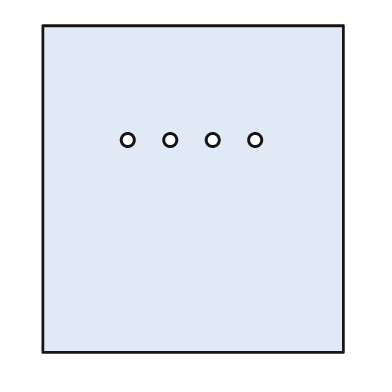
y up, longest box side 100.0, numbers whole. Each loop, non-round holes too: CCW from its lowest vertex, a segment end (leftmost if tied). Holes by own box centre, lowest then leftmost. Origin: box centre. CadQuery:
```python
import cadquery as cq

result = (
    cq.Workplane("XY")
    .moveTo(-46.0, -50.0)
    .lineTo(46.0, -50.0)
    .lineTo(46.0, 50.0)
    .lineTo(-46.0, 50.0)
    .close()
    .moveTo(-20.0, 15.0)
    .circle(2.0)
    .moveTo(-7.0, 15.0)
    .circle(2.0)
    .moveTo(6.0, 15.0)
    .circle(2.0)
    .moveTo(19.0, 15.0)
    .circle(2.0)
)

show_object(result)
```